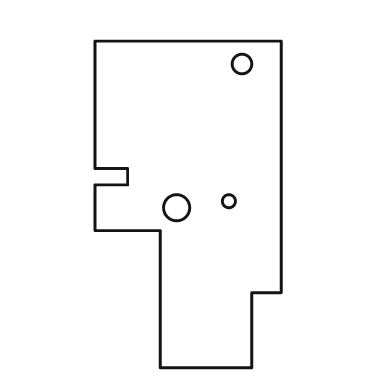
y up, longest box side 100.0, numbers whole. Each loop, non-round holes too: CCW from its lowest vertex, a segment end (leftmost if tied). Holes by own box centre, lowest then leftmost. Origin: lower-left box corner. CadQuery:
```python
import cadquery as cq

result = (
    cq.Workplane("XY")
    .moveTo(20.0, 0.0)
    .lineTo(48.0, 0.0)
    .lineTo(48.0, 23.0)
    .lineTo(57.0, 23.0)
    .lineTo(57.0, 100.0)
    .lineTo(0.0, 100.0)
    .lineTo(0.0, 61.0)
    .lineTo(10.0, 61.0)
    .lineTo(10.0, 56.0)
    .lineTo(0.0, 56.0)
    .lineTo(0.0, 42.0)
    .lineTo(20.0, 42.0)
    .close()
    .moveTo(25.0, 49.0)
    .circle(4.0)
    .moveTo(41.0, 51.0)
    .circle(2.0)
    .moveTo(45.0, 93.0)
    .circle(3.0)
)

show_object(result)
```